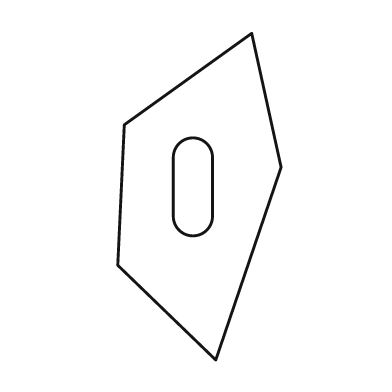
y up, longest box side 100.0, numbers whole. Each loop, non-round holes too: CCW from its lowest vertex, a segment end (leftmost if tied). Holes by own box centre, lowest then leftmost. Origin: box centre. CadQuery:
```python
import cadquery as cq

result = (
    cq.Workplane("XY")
    .moveTo(5.0, -50.0)
    .lineTo(25.0, 9.0)
    .lineTo(16.0, 50.0)
    .lineTo(-23.0, 22.0)
    .lineTo(-25.0, -21.0)
    .close()
    .moveTo(-8.0, -6.0)
    .threePointArc((-2.0, -12.0), (4.0, -6.0))
    .lineTo(4.0, 12.0)
    .threePointArc((-2.0, 18.0), (-8.0, 12.0))
    .close()
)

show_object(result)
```